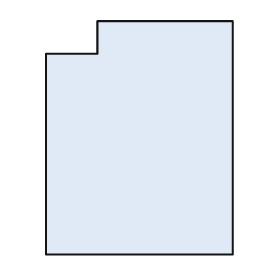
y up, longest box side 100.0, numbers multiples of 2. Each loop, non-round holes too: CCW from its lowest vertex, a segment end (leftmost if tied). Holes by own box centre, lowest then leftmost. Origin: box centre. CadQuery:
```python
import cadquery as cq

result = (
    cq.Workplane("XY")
    .moveTo(-40.0, -50.0)
    .lineTo(40.0, -50.0)
    .lineTo(40.0, 50.0)
    .lineTo(-18.0, 50.0)
    .lineTo(-18.0, 36.0)
    .lineTo(-40.0, 36.0)
    .close()
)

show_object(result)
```